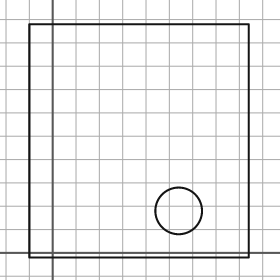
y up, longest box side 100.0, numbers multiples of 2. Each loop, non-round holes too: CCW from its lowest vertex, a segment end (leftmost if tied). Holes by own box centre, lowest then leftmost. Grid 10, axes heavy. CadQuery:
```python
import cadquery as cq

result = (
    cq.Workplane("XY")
    .moveTo(-10.0, -2.0)
    .lineTo(84.0, -2.0)
    .lineTo(84.0, 98.0)
    .lineTo(-10.0, 98.0)
    .close()
    .moveTo(54.0, 18.0)
    .circle(10.0)
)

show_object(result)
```